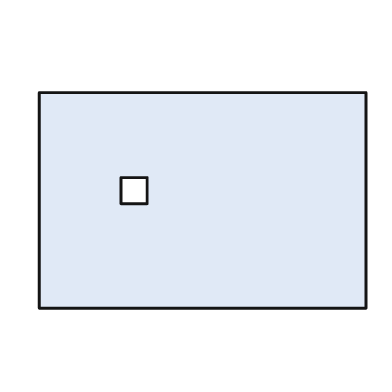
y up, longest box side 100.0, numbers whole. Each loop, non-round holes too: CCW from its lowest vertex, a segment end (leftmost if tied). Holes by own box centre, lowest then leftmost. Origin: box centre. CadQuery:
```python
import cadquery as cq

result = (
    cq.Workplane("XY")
    .moveTo(-50.0, -33.0)
    .lineTo(50.0, -33.0)
    .lineTo(50.0, 33.0)
    .lineTo(-50.0, 33.0)
    .close()
    .moveTo(-25.0, -1.0)
    .lineTo(-17.0, -1.0)
    .lineTo(-17.0, 7.0)
    .lineTo(-25.0, 7.0)
    .close()
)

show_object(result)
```